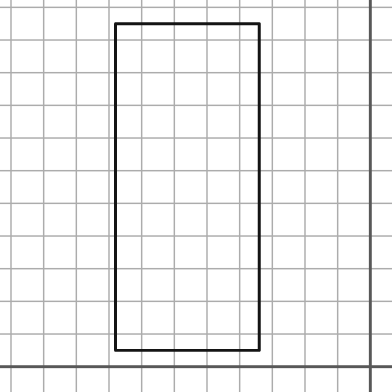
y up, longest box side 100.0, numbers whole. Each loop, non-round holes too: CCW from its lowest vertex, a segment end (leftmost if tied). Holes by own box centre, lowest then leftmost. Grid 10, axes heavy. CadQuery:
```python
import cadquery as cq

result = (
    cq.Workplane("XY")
    .moveTo(-78.0, 5.0)
    .lineTo(-34.0, 5.0)
    .lineTo(-34.0, 105.0)
    .lineTo(-78.0, 105.0)
    .close()
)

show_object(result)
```